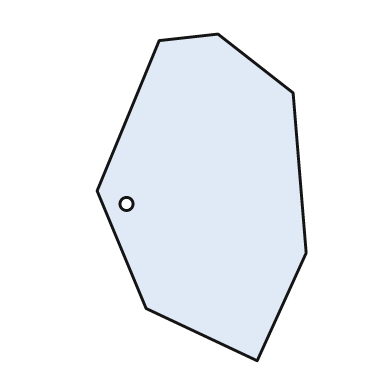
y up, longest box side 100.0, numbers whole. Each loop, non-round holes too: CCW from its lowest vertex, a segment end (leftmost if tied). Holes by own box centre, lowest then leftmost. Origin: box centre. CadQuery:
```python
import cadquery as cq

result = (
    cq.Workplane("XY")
    .moveTo(17.0, -50.0)
    .lineTo(32.0, -17.0)
    .lineTo(28.0, 32.0)
    .lineTo(5.0, 50.0)
    .lineTo(-13.0, 48.0)
    .lineTo(-32.0, 2.0)
    .lineTo(-17.0, -34.0)
    .close()
    .moveTo(-23.0, -2.0)
    .circle(2.0)
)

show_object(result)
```